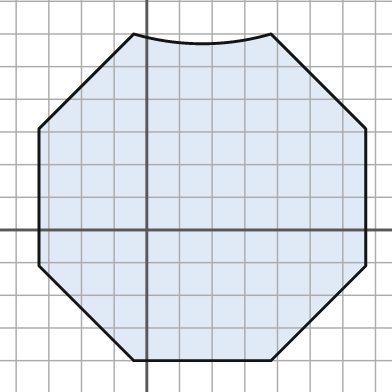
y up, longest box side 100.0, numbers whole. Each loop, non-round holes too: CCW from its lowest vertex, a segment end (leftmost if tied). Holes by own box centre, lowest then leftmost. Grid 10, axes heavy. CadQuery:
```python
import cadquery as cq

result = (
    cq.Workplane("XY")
    .moveTo(-4.0, -40.0)
    .lineTo(38.0, -40.0)
    .lineTo(67.0, -11.0)
    .lineTo(67.0, 31.0)
    .lineTo(38.0, 60.0)
    .threePointArc((17.0, 57.0), (-4.0, 60.0))
    .lineTo(-33.0, 31.0)
    .lineTo(-33.0, -11.0)
    .close()
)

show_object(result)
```